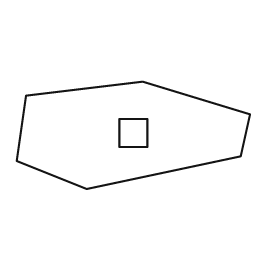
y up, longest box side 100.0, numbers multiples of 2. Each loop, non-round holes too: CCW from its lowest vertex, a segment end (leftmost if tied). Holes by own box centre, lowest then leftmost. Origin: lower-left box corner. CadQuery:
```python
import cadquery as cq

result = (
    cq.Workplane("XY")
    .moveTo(30.0, 0.0)
    .lineTo(96.0, 14.0)
    .lineTo(100.0, 32.0)
    .lineTo(54.0, 46.0)
    .lineTo(4.0, 40.0)
    .lineTo(0.0, 12.0)
    .close()
    .moveTo(44.0, 18.0)
    .lineTo(56.0, 18.0)
    .lineTo(56.0, 30.0)
    .lineTo(44.0, 30.0)
    .close()
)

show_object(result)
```